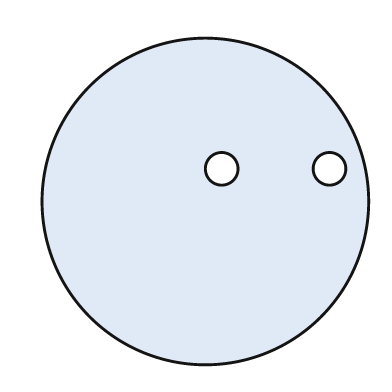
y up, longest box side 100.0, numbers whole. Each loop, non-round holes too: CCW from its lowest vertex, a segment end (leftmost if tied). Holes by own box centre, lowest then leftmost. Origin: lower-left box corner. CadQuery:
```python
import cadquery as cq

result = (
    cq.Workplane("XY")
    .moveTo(50.0, 50.0)
    .circle(50.0)
    .moveTo(55.0, 60.0)
    .circle(5.0)
    .moveTo(88.0, 60.0)
    .circle(5.0)
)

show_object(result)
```